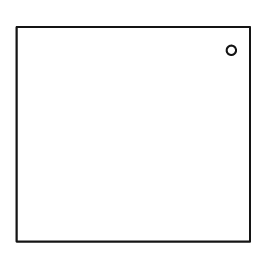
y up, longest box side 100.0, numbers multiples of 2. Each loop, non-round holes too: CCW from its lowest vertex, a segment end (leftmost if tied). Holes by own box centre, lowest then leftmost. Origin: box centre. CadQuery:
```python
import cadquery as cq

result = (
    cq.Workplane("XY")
    .moveTo(-50.0, -46.0)
    .lineTo(50.0, -46.0)
    .lineTo(50.0, 46.0)
    .lineTo(-50.0, 46.0)
    .close()
    .moveTo(42.0, 36.0)
    .circle(2.0)
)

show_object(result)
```